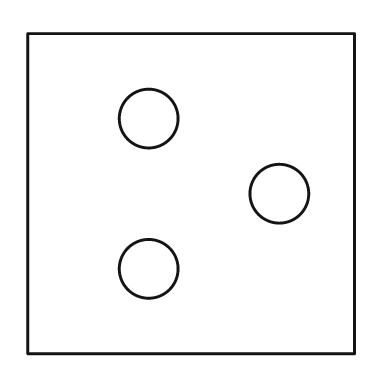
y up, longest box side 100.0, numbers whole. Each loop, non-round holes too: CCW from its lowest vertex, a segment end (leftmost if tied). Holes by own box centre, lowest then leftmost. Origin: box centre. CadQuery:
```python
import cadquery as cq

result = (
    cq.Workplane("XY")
    .moveTo(-50.0, -49.0)
    .lineTo(50.0, -49.0)
    .lineTo(50.0, 49.0)
    .lineTo(-50.0, 49.0)
    .close()
    .moveTo(-13.0, -23.0)
    .circle(9.0)
    .moveTo(27.0, 0.0)
    .circle(9.0)
    .moveTo(-13.0, 23.0)
    .circle(9.0)
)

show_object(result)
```